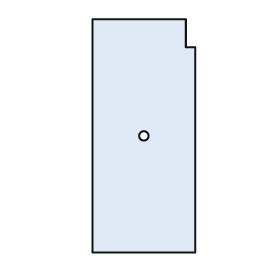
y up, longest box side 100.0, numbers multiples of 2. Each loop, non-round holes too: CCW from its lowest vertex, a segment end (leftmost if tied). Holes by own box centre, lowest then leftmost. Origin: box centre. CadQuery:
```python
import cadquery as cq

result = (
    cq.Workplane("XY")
    .moveTo(-22.0, -50.0)
    .lineTo(22.0, -50.0)
    .lineTo(22.0, 38.0)
    .lineTo(18.0, 38.0)
    .lineTo(18.0, 50.0)
    .lineTo(-22.0, 50.0)
    .close()
    .moveTo(0.0, 0.0)
    .circle(2.0)
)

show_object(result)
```